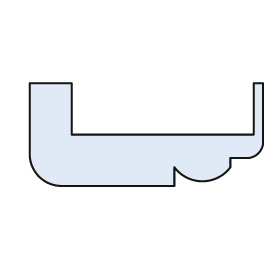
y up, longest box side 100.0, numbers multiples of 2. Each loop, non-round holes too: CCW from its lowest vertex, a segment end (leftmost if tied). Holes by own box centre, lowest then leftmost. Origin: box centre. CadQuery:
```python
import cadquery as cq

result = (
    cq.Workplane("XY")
    .moveTo(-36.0, -22.0)
    .lineTo(12.0, -22.0)
    .lineTo(12.0, -14.0)
    .threePointArc((24.0, -20.0), (36.0, -14.0))
    .lineTo(36.0, -10.0)
    .lineTo(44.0, -10.0)
    .threePointArc((48.0, -8.0), (50.0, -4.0))
    .lineTo(50.0, 22.0)
    .lineTo(46.0, 22.0)
    .lineTo(46.0, 0.0)
    .lineTo(-32.0, 0.0)
    .lineTo(-32.0, 22.0)
    .lineTo(-50.0, 22.0)
    .lineTo(-50.0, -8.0)
    .threePointArc((-46.0, -18.0), (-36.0, -22.0))
    .close()
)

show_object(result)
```